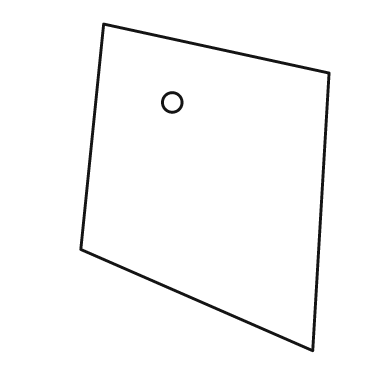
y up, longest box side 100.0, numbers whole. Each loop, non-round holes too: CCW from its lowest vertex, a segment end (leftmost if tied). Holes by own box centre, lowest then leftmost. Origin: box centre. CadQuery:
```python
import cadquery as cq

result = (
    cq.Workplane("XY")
    .moveTo(33.0, -50.0)
    .lineTo(38.0, 35.0)
    .lineTo(-31.0, 50.0)
    .lineTo(-38.0, -19.0)
    .close()
    .moveTo(-10.0, 26.0)
    .circle(3.0)
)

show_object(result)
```